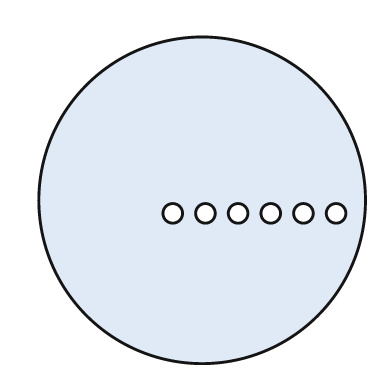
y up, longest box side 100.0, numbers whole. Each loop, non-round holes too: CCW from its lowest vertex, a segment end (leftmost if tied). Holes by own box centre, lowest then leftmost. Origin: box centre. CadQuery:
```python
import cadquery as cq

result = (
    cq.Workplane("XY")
    .moveTo(0.0, 0.0)
    .circle(50.0)
    .moveTo(-9.0, -4.0)
    .circle(3.0)
    .moveTo(1.0, -4.0)
    .circle(3.0)
    .moveTo(11.0, -4.0)
    .circle(3.0)
    .moveTo(21.0, -4.0)
    .circle(3.0)
    .moveTo(31.0, -4.0)
    .circle(3.0)
    .moveTo(41.0, -4.0)
    .circle(3.0)
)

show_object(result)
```